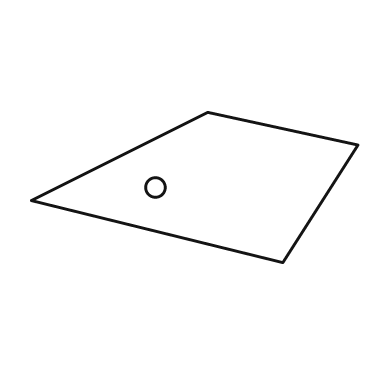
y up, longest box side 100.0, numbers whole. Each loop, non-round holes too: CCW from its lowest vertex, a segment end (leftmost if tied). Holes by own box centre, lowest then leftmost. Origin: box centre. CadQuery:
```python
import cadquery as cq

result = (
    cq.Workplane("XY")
    .moveTo(27.0, -23.0)
    .lineTo(50.0, 13.0)
    .lineTo(4.0, 23.0)
    .lineTo(-50.0, -4.0)
    .close()
    .moveTo(-12.0, 0.0)
    .circle(3.0)
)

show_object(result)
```